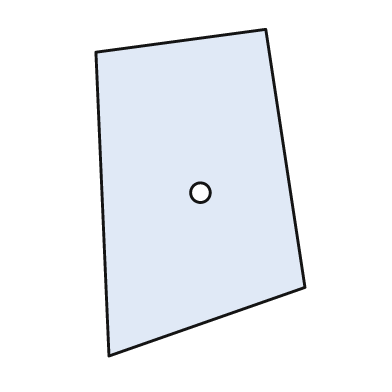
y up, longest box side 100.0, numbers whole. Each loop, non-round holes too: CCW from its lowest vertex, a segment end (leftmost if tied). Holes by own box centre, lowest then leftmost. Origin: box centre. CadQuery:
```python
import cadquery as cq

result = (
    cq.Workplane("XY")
    .moveTo(-28.0, -50.0)
    .lineTo(32.0, -29.0)
    .lineTo(20.0, 50.0)
    .lineTo(-32.0, 43.0)
    .close()
    .moveTo(0.0, 0.0)
    .circle(3.0)
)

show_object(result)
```